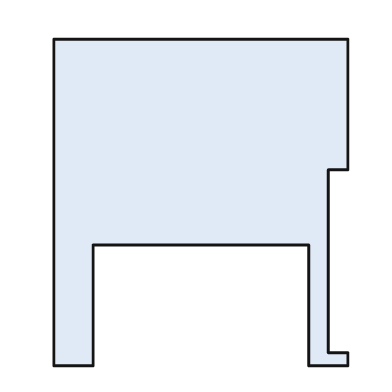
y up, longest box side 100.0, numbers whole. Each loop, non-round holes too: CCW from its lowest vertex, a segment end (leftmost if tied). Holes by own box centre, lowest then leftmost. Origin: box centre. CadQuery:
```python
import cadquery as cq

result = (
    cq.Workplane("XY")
    .moveTo(-45.0, -50.0)
    .lineTo(-33.0, -50.0)
    .lineTo(-33.0, -13.0)
    .lineTo(33.0, -13.0)
    .lineTo(33.0, -50.0)
    .lineTo(45.0, -50.0)
    .lineTo(45.0, -46.0)
    .lineTo(39.0, -46.0)
    .lineTo(39.0, 10.0)
    .lineTo(45.0, 10.0)
    .lineTo(45.0, 50.0)
    .lineTo(-45.0, 50.0)
    .close()
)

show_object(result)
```